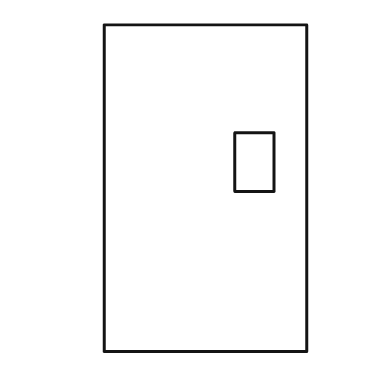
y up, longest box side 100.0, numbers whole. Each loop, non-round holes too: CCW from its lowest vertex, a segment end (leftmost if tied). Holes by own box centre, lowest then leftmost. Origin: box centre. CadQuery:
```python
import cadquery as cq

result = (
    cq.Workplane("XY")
    .moveTo(-31.0, -50.0)
    .lineTo(31.0, -50.0)
    .lineTo(31.0, 50.0)
    .lineTo(-31.0, 50.0)
    .close()
    .moveTo(9.0, -1.0)
    .lineTo(21.0, -1.0)
    .lineTo(21.0, 17.0)
    .lineTo(9.0, 17.0)
    .close()
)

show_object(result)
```